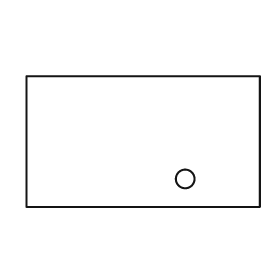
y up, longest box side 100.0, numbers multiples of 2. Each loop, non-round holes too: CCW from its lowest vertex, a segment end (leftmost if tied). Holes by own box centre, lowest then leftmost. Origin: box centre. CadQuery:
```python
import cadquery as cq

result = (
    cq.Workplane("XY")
    .moveTo(-50.0, -28.0)
    .lineTo(50.0, -28.0)
    .lineTo(50.0, 28.0)
    .lineTo(-50.0, 28.0)
    .close()
    .moveTo(18.0, -16.0)
    .circle(4.0)
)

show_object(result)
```